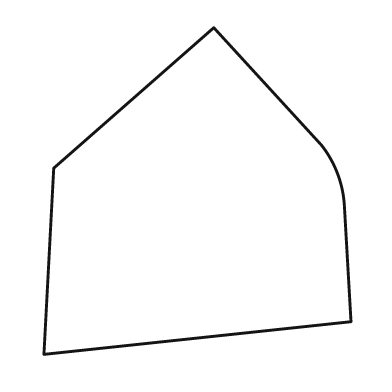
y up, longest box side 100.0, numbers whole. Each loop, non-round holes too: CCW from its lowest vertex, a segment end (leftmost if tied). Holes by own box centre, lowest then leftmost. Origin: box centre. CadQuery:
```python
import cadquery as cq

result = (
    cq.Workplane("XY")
    .moveTo(-47.0, -50.0)
    .lineTo(47.0, -40.0)
    .lineTo(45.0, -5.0)
    .threePointArc((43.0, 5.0), (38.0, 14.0))
    .lineTo(5.0, 50.0)
    .lineTo(-44.0, 7.0)
    .close()
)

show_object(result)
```